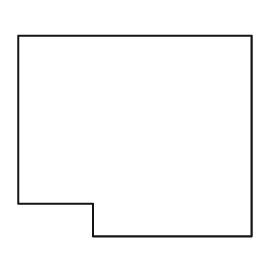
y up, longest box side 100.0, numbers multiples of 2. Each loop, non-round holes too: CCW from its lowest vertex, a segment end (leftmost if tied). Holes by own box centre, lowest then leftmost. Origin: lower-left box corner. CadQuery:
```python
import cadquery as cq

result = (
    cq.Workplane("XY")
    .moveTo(32.0, 0.0)
    .lineTo(100.0, 0.0)
    .lineTo(100.0, 86.0)
    .lineTo(0.0, 86.0)
    .lineTo(0.0, 14.0)
    .lineTo(32.0, 14.0)
    .close()
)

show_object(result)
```